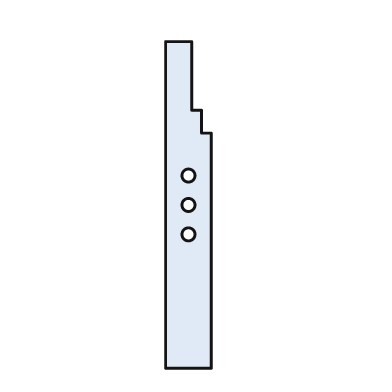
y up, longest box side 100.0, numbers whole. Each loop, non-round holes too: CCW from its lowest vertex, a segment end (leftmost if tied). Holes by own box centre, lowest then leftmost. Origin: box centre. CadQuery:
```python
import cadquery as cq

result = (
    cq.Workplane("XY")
    .moveTo(-7.0, -50.0)
    .lineTo(7.0, -50.0)
    .lineTo(7.0, 22.0)
    .lineTo(4.0, 22.0)
    .lineTo(4.0, 29.0)
    .lineTo(1.0, 29.0)
    .lineTo(1.0, 50.0)
    .lineTo(-7.0, 50.0)
    .close()
    .moveTo(0.0, -9.0)
    .circle(2.0)
    .moveTo(0.0, 0.0)
    .circle(2.0)
    .moveTo(0.0, 9.0)
    .circle(2.0)
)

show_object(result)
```